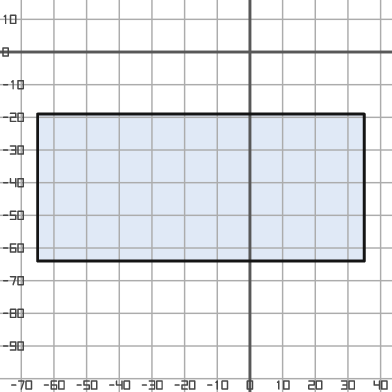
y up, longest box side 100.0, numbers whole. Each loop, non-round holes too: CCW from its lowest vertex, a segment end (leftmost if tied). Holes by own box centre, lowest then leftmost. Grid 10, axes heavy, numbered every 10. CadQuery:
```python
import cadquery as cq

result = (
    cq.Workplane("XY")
    .moveTo(-65.0, -64.0)
    .lineTo(35.0, -64.0)
    .lineTo(35.0, -19.0)
    .lineTo(-65.0, -19.0)
    .close()
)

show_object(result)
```